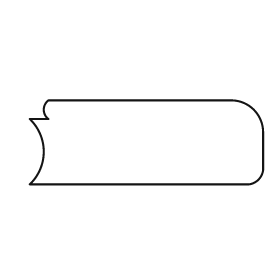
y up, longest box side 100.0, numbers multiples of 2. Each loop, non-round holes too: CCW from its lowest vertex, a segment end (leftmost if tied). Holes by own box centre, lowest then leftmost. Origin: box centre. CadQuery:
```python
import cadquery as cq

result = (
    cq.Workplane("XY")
    .moveTo(-50.0, -18.0)
    .lineTo(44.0, -18.0)
    .threePointArc((48.0, -16.0), (50.0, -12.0))
    .lineTo(50.0, 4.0)
    .threePointArc((46.0, 14.0), (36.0, 18.0))
    .lineTo(-42.0, 18.0)
    .threePointArc((-44.0, 14.0), (-42.0, 10.0))
    .lineTo(-50.0, 10.0)
    .threePointArc((-44.0, -4.0), (-50.0, -18.0))
    .close()
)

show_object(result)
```